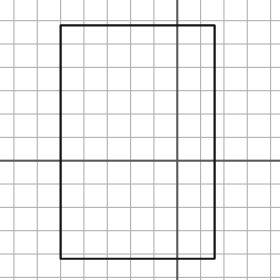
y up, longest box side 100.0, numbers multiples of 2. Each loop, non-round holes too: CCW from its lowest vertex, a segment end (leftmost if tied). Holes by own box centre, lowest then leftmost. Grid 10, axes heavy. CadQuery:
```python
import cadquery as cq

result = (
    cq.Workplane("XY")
    .moveTo(-50.0, -42.0)
    .lineTo(16.0, -42.0)
    .lineTo(16.0, 58.0)
    .lineTo(-50.0, 58.0)
    .close()
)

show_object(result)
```